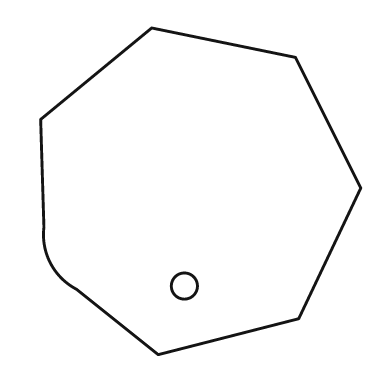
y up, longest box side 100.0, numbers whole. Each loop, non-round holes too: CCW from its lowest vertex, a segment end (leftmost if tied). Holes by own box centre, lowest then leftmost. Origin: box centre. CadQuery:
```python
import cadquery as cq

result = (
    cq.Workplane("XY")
    .moveTo(-13.0, -50.0)
    .lineTo(30.0, -39.0)
    .lineTo(49.0, 1.0)
    .lineTo(29.0, 41.0)
    .lineTo(-15.0, 50.0)
    .lineTo(-49.0, 22.0)
    .lineTo(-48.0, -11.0)
    .threePointArc((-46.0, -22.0), (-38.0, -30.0))
    .close()
    .moveTo(-5.0, -29.0)
    .circle(4.0)
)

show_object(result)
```